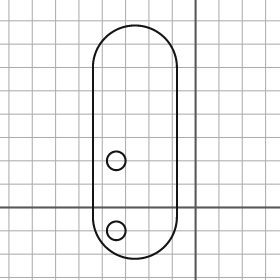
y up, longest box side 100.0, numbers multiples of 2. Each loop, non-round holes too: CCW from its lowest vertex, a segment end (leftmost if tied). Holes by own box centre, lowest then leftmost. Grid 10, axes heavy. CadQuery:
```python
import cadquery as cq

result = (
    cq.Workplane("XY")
    .moveTo(-44.0, -4.0)
    .threePointArc((-26.0, -22.0), (-8.0, -4.0))
    .lineTo(-8.0, 60.0)
    .threePointArc((-26.0, 78.0), (-44.0, 60.0))
    .close()
    .moveTo(-34.0, -10.0)
    .circle(4.0)
    .moveTo(-34.0, 20.0)
    .circle(4.0)
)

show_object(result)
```